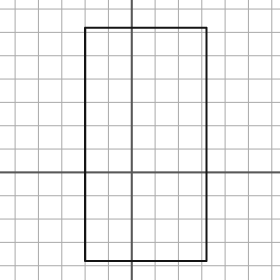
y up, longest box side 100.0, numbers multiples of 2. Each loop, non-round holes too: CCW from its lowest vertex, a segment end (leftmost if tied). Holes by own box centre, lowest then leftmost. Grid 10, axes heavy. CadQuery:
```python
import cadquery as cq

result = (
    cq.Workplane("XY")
    .moveTo(-20.0, -38.0)
    .lineTo(32.0, -38.0)
    .lineTo(32.0, 62.0)
    .lineTo(-20.0, 62.0)
    .close()
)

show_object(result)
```